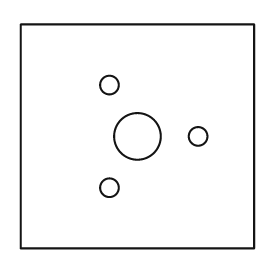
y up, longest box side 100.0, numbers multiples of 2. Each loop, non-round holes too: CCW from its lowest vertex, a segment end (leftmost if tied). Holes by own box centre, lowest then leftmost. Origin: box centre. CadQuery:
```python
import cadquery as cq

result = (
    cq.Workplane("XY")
    .moveTo(-50.0, -48.0)
    .lineTo(50.0, -48.0)
    .lineTo(50.0, 48.0)
    .lineTo(-50.0, 48.0)
    .close()
    .moveTo(-12.0, -22.0)
    .circle(4.0)
    .moveTo(0.0, 0.0)
    .circle(10.0)
    .moveTo(26.0, 0.0)
    .circle(4.0)
    .moveTo(-12.0, 22.0)
    .circle(4.0)
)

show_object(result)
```